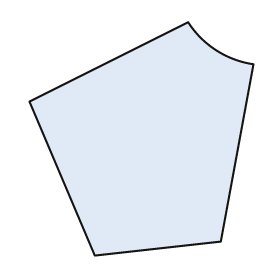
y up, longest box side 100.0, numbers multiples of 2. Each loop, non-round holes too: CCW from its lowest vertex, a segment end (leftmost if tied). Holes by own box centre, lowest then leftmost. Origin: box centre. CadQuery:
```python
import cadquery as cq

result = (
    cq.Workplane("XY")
    .moveTo(-20.0, -50.0)
    .lineTo(34.0, -44.0)
    .lineTo(48.0, 32.0)
    .threePointArc((32.0, 38.0), (20.0, 50.0))
    .lineTo(-48.0, 16.0)
    .close()
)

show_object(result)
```